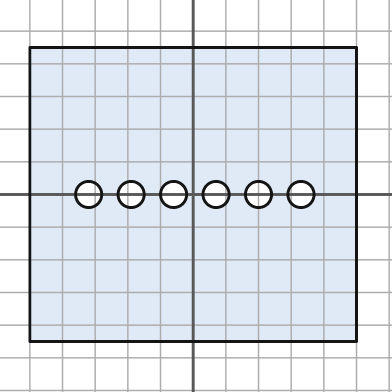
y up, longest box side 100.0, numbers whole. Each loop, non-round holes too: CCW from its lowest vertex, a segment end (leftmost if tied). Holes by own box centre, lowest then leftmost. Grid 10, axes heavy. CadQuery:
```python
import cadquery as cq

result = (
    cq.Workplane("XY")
    .moveTo(-50.0, -45.0)
    .lineTo(50.0, -45.0)
    .lineTo(50.0, 45.0)
    .lineTo(-50.0, 45.0)
    .close()
    .moveTo(-32.0, 0.0)
    .circle(4.0)
    .moveTo(-19.0, 0.0)
    .circle(4.0)
    .moveTo(-6.0, 0.0)
    .circle(4.0)
    .moveTo(7.0, 0.0)
    .circle(4.0)
    .moveTo(20.0, 0.0)
    .circle(4.0)
    .moveTo(33.0, 0.0)
    .circle(4.0)
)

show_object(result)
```